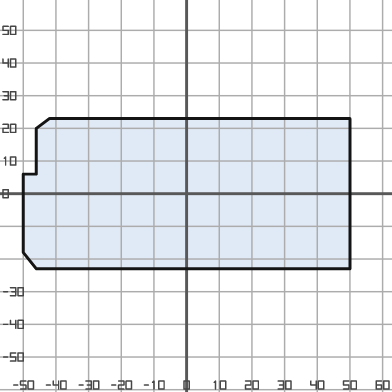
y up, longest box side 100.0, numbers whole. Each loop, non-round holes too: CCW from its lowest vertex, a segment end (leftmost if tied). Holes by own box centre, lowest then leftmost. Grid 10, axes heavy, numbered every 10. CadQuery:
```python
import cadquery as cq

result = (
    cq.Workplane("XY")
    .moveTo(-46.0, -23.0)
    .lineTo(50.0, -23.0)
    .lineTo(50.0, 23.0)
    .lineTo(-42.0, 23.0)
    .lineTo(-46.0, 20.0)
    .lineTo(-46.0, 6.0)
    .lineTo(-50.0, 6.0)
    .lineTo(-50.0, -18.0)
    .close()
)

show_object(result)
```